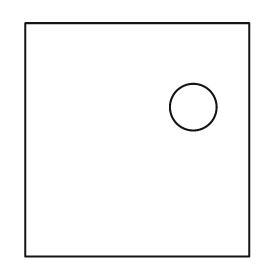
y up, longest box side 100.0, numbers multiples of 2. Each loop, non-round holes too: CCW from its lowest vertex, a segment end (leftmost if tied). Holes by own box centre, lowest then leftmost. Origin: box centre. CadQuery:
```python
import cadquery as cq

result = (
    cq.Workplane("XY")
    .moveTo(-48.0, -50.0)
    .lineTo(48.0, -50.0)
    .lineTo(48.0, 50.0)
    .lineTo(-48.0, 50.0)
    .close()
    .moveTo(24.0, 14.0)
    .circle(10.0)
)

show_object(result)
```